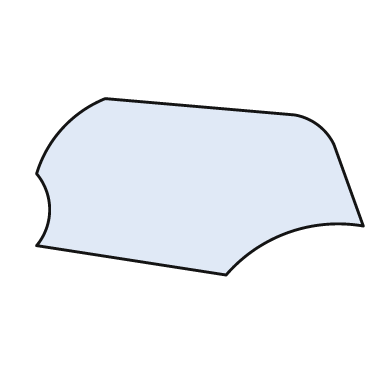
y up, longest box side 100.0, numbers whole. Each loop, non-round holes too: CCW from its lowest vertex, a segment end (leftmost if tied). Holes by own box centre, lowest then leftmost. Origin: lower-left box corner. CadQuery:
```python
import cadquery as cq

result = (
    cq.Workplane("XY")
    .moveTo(58.0, 0.0)
    .threePointArc((77.0, 13.0), (100.0, 15.0))
    .lineTo(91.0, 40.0)
    .threePointArc((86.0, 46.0), (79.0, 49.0))
    .lineTo(21.0, 54.0)
    .threePointArc((8.0, 45.0), (0.0, 31.0))
    .threePointArc((4.0, 20.0), (0.0, 9.0))
    .close()
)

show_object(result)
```